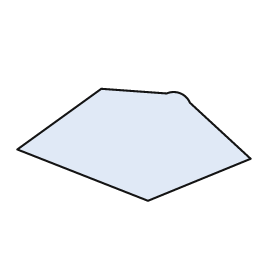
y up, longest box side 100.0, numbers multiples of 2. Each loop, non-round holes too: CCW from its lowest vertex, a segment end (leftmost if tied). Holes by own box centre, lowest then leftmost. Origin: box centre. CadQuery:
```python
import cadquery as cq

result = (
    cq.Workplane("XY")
    .moveTo(6.0, -24.0)
    .lineTo(50.0, -6.0)
    .lineTo(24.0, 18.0)
    .threePointArc((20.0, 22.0), (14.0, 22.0))
    .lineTo(-14.0, 24.0)
    .lineTo(-50.0, -2.0)
    .close()
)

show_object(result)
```